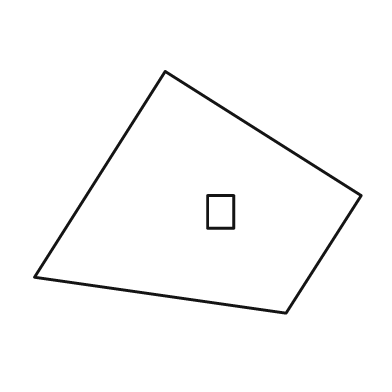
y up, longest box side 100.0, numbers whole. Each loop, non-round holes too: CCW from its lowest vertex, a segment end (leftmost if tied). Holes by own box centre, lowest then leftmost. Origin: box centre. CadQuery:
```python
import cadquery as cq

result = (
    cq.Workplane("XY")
    .moveTo(27.0, -37.0)
    .lineTo(50.0, -1.0)
    .lineTo(-10.0, 37.0)
    .lineTo(-50.0, -26.0)
    .close()
    .moveTo(3.0, -11.0)
    .lineTo(11.0, -11.0)
    .lineTo(11.0, -1.0)
    .lineTo(3.0, -1.0)
    .close()
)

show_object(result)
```